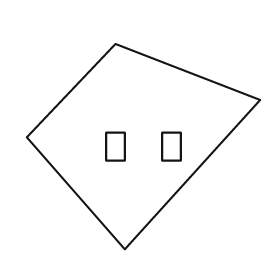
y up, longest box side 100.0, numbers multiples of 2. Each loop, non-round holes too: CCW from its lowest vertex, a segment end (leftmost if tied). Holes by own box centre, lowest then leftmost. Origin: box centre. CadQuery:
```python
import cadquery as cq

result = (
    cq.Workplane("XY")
    .moveTo(-8.0, -44.0)
    .lineTo(50.0, 20.0)
    .lineTo(-12.0, 44.0)
    .lineTo(-50.0, 4.0)
    .close()
    .moveTo(-16.0, -6.0)
    .lineTo(-8.0, -6.0)
    .lineTo(-8.0, 6.0)
    .lineTo(-16.0, 6.0)
    .close()
    .moveTo(8.0, -6.0)
    .lineTo(16.0, -6.0)
    .lineTo(16.0, 6.0)
    .lineTo(8.0, 6.0)
    .close()
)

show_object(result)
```